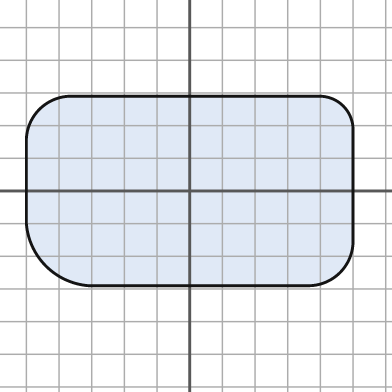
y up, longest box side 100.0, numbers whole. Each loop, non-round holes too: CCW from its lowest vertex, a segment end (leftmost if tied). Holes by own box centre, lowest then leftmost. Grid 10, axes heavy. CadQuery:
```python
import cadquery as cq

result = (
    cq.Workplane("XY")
    .moveTo(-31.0, -29.0)
    .lineTo(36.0, -29.0)
    .threePointArc((46.0, -25.0), (50.0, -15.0))
    .lineTo(50.0, 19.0)
    .threePointArc((47.0, 26.0), (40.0, 29.0))
    .lineTo(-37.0, 29.0)
    .threePointArc((-46.0, 25.0), (-50.0, 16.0))
    .lineTo(-50.0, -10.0)
    .threePointArc((-44.0, -23.0), (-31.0, -29.0))
    .close()
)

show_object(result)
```